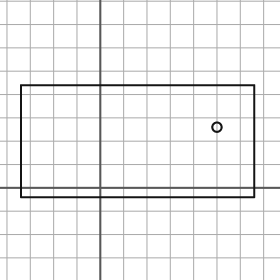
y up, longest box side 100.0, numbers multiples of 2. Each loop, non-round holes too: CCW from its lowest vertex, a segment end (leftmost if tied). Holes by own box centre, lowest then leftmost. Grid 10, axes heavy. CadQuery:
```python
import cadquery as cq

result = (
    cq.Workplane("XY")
    .moveTo(-34.0, -4.0)
    .lineTo(66.0, -4.0)
    .lineTo(66.0, 44.0)
    .lineTo(-34.0, 44.0)
    .close()
    .moveTo(50.0, 26.0)
    .circle(2.0)
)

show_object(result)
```